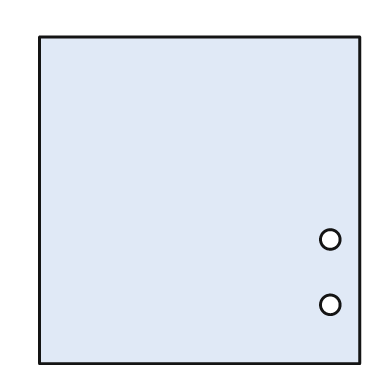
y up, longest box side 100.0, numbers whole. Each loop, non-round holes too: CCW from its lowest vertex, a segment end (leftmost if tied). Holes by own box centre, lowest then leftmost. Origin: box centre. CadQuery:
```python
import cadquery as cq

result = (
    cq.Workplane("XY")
    .moveTo(-49.0, -50.0)
    .lineTo(49.0, -50.0)
    .lineTo(49.0, 50.0)
    .lineTo(-49.0, 50.0)
    .close()
    .moveTo(40.0, -32.0)
    .circle(3.0)
    .moveTo(40.0, -12.0)
    .circle(3.0)
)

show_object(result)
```